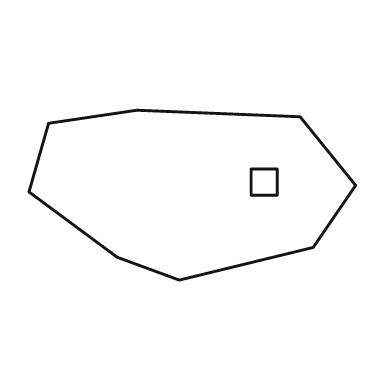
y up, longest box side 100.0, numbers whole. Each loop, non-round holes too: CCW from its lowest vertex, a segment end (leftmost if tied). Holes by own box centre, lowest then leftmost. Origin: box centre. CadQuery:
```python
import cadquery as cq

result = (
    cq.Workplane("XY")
    .moveTo(-4.0, -26.0)
    .lineTo(37.0, -16.0)
    .lineTo(50.0, 3.0)
    .lineTo(33.0, 24.0)
    .lineTo(-17.0, 26.0)
    .lineTo(-44.0, 22.0)
    .lineTo(-50.0, 1.0)
    .lineTo(-23.0, -19.0)
    .close()
    .moveTo(18.0, 0.0)
    .lineTo(26.0, 0.0)
    .lineTo(26.0, 8.0)
    .lineTo(18.0, 8.0)
    .close()
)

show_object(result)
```